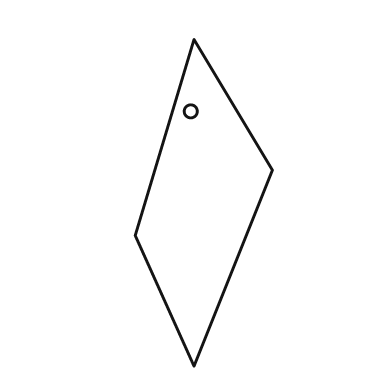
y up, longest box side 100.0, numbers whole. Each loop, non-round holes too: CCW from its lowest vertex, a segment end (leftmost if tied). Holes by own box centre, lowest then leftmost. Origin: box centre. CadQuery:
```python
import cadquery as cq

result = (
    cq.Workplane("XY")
    .moveTo(-3.0, -50.0)
    .lineTo(21.0, 10.0)
    .lineTo(-3.0, 50.0)
    .lineTo(-21.0, -10.0)
    .close()
    .moveTo(-4.0, 28.0)
    .circle(2.0)
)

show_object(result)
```